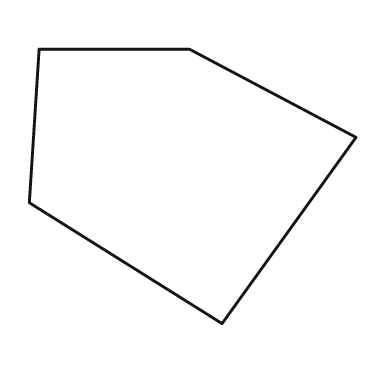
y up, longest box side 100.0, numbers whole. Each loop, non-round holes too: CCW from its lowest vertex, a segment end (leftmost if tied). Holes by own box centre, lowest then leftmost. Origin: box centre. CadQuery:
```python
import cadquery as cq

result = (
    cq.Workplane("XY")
    .moveTo(9.0, -42.0)
    .lineTo(50.0, 15.0)
    .lineTo(-1.0, 42.0)
    .lineTo(-47.0, 42.0)
    .lineTo(-50.0, -5.0)
    .close()
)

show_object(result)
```